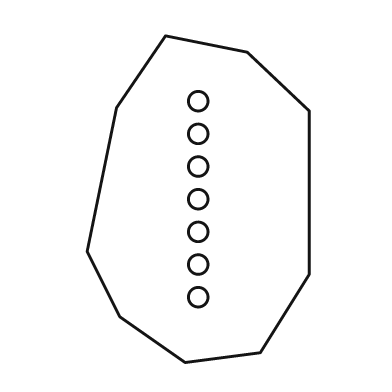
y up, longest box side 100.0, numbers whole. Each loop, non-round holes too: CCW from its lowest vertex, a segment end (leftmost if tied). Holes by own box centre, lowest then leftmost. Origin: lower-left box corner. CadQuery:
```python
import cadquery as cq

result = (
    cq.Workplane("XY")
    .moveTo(30.0, 0.0)
    .lineTo(53.0, 3.0)
    .lineTo(68.0, 27.0)
    .lineTo(68.0, 77.0)
    .lineTo(49.0, 95.0)
    .lineTo(24.0, 100.0)
    .lineTo(9.0, 78.0)
    .lineTo(0.0, 34.0)
    .lineTo(10.0, 14.0)
    .close()
    .moveTo(34.0, 20.0)
    .circle(3.0)
    .moveTo(34.0, 30.0)
    .circle(3.0)
    .moveTo(34.0, 40.0)
    .circle(3.0)
    .moveTo(34.0, 50.0)
    .circle(3.0)
    .moveTo(34.0, 60.0)
    .circle(3.0)
    .moveTo(34.0, 70.0)
    .circle(3.0)
    .moveTo(34.0, 80.0)
    .circle(3.0)
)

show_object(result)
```